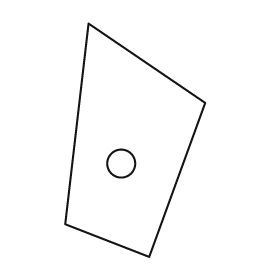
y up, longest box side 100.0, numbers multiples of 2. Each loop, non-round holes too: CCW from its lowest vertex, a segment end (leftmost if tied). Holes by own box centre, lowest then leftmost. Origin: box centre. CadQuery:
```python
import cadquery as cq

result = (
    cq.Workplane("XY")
    .moveTo(6.0, -50.0)
    .lineTo(30.0, 16.0)
    .lineTo(-20.0, 50.0)
    .lineTo(-30.0, -36.0)
    .close()
    .moveTo(-6.0, -10.0)
    .circle(6.0)
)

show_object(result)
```